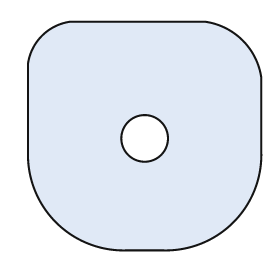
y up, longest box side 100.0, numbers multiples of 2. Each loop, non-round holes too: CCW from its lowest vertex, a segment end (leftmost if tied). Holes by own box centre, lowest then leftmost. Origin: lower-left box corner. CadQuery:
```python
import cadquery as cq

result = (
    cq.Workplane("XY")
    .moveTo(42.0, 0.0)
    .lineTo(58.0, 0.0)
    .threePointArc((88.0, 12.0), (100.0, 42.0))
    .lineTo(100.0, 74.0)
    .threePointArc((92.0, 90.0), (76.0, 98.0))
    .lineTo(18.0, 98.0)
    .threePointArc((6.0, 92.0), (0.0, 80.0))
    .lineTo(0.0, 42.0)
    .threePointArc((12.0, 12.0), (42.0, 0.0))
    .close()
    .moveTo(50.0, 48.0)
    .circle(10.0)
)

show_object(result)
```